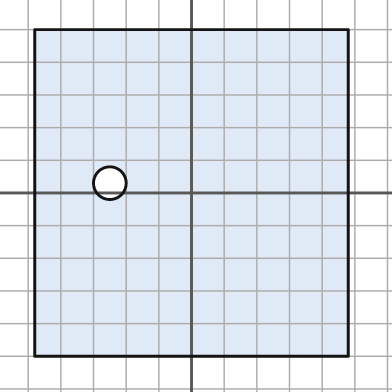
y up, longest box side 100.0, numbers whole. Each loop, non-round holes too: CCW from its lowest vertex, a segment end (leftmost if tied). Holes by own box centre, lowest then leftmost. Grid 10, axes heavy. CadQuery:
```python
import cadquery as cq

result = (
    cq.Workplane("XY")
    .moveTo(-48.0, -50.0)
    .lineTo(48.0, -50.0)
    .lineTo(48.0, 50.0)
    .lineTo(-48.0, 50.0)
    .close()
    .moveTo(-25.0, 3.0)
    .circle(5.0)
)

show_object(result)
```